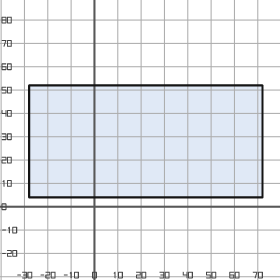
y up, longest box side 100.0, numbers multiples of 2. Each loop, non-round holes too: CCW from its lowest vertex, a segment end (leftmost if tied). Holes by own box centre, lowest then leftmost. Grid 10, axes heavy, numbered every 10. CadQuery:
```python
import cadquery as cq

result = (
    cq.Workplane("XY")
    .moveTo(-28.0, 4.0)
    .lineTo(72.0, 4.0)
    .lineTo(72.0, 52.0)
    .lineTo(-28.0, 52.0)
    .close()
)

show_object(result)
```